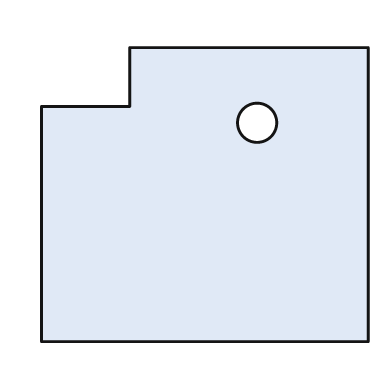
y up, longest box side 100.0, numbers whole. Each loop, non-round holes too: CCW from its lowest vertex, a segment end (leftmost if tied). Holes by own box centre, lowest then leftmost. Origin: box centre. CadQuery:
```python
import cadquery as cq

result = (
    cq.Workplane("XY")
    .moveTo(-50.0, -45.0)
    .lineTo(50.0, -45.0)
    .lineTo(50.0, 45.0)
    .lineTo(-23.0, 45.0)
    .lineTo(-23.0, 27.0)
    .lineTo(-50.0, 27.0)
    .close()
    .moveTo(16.0, 22.0)
    .circle(6.0)
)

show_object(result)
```